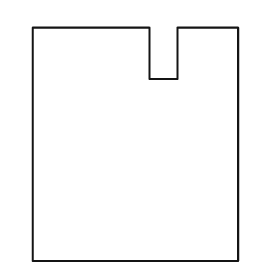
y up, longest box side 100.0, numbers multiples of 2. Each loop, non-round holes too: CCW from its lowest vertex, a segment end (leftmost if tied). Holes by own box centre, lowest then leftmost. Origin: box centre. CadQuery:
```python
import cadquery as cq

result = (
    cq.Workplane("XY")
    .moveTo(-44.0, -50.0)
    .lineTo(44.0, -50.0)
    .lineTo(44.0, 50.0)
    .lineTo(18.0, 50.0)
    .lineTo(18.0, 28.0)
    .lineTo(6.0, 28.0)
    .lineTo(6.0, 50.0)
    .lineTo(-44.0, 50.0)
    .close()
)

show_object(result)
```